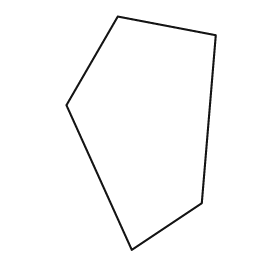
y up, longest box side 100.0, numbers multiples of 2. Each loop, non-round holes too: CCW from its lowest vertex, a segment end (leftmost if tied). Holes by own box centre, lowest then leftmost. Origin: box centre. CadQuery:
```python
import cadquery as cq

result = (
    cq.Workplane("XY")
    .moveTo(-4.0, -50.0)
    .lineTo(26.0, -30.0)
    .lineTo(32.0, 42.0)
    .lineTo(-10.0, 50.0)
    .lineTo(-32.0, 12.0)
    .close()
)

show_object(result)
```